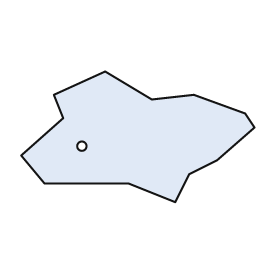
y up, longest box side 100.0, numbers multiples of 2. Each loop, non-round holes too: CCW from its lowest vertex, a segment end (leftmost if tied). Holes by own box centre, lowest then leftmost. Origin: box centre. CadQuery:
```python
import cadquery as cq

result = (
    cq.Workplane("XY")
    .moveTo(16.0, -28.0)
    .lineTo(22.0, -16.0)
    .lineTo(34.0, -10.0)
    .lineTo(50.0, 4.0)
    .lineTo(46.0, 10.0)
    .lineTo(24.0, 18.0)
    .lineTo(6.0, 16.0)
    .lineTo(-14.0, 28.0)
    .lineTo(-36.0, 18.0)
    .lineTo(-32.0, 8.0)
    .lineTo(-50.0, -8.0)
    .lineTo(-40.0, -20.0)
    .lineTo(-4.0, -20.0)
    .close()
    .moveTo(-24.0, -4.0)
    .circle(2.0)
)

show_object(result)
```